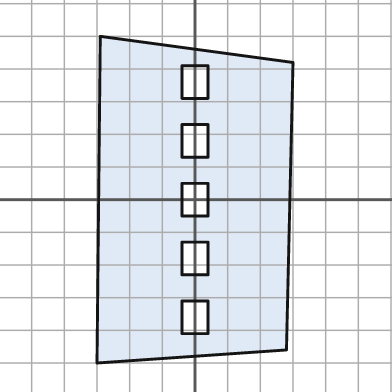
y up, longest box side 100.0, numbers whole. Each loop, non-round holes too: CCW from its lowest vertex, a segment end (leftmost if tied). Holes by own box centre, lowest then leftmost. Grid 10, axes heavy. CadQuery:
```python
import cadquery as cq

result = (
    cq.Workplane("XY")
    .moveTo(-30.0, -50.0)
    .lineTo(28.0, -46.0)
    .lineTo(30.0, 42.0)
    .lineTo(-29.0, 50.0)
    .close()
    .moveTo(-4.0, -41.0)
    .lineTo(4.0, -41.0)
    .lineTo(4.0, -31.0)
    .lineTo(-4.0, -31.0)
    .close()
    .moveTo(-4.0, -23.0)
    .lineTo(4.0, -23.0)
    .lineTo(4.0, -13.0)
    .lineTo(-4.0, -13.0)
    .close()
    .moveTo(-4.0, -5.0)
    .lineTo(4.0, -5.0)
    .lineTo(4.0, 5.0)
    .lineTo(-4.0, 5.0)
    .close()
    .moveTo(-4.0, 13.0)
    .lineTo(4.0, 13.0)
    .lineTo(4.0, 23.0)
    .lineTo(-4.0, 23.0)
    .close()
    .moveTo(-4.0, 31.0)
    .lineTo(4.0, 31.0)
    .lineTo(4.0, 41.0)
    .lineTo(-4.0, 41.0)
    .close()
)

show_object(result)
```